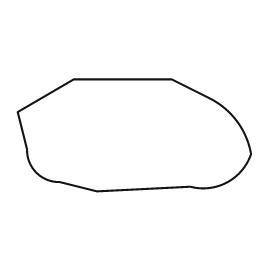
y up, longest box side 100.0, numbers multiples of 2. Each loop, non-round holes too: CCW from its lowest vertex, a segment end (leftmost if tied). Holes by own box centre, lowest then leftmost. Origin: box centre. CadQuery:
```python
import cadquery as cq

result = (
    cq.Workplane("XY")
    .moveTo(-16.0, -24.0)
    .lineTo(24.0, -22.0)
    .threePointArc((40.0, -20.0), (50.0, -8.0))
    .threePointArc((44.0, 6.0), (32.0, 16.0))
    .lineTo(16.0, 24.0)
    .lineTo(-26.0, 24.0)
    .lineTo(-50.0, 10.0)
    .lineTo(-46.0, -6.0)
    .threePointArc((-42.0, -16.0), (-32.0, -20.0))
    .close()
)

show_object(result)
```